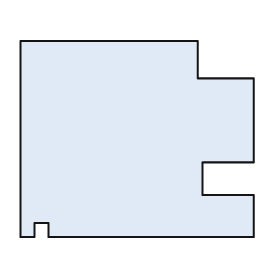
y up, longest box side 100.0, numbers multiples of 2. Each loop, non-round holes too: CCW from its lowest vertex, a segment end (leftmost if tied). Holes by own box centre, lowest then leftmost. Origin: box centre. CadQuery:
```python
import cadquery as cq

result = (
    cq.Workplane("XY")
    .moveTo(-50.0, -42.0)
    .lineTo(-44.0, -42.0)
    .lineTo(-44.0, -36.0)
    .lineTo(-38.0, -36.0)
    .lineTo(-38.0, -42.0)
    .lineTo(50.0, -42.0)
    .lineTo(50.0, -24.0)
    .lineTo(28.0, -24.0)
    .lineTo(28.0, -10.0)
    .lineTo(50.0, -10.0)
    .lineTo(50.0, 26.0)
    .lineTo(26.0, 26.0)
    .lineTo(26.0, 42.0)
    .lineTo(-50.0, 42.0)
    .close()
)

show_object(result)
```